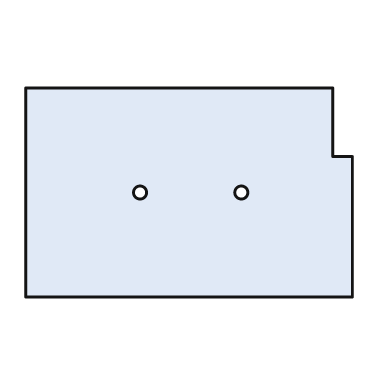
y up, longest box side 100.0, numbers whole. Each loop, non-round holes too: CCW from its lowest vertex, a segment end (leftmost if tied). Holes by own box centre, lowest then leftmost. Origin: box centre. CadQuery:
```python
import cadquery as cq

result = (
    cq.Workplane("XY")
    .moveTo(-50.0, -32.0)
    .lineTo(50.0, -32.0)
    .lineTo(50.0, 11.0)
    .lineTo(44.0, 11.0)
    .lineTo(44.0, 32.0)
    .lineTo(-50.0, 32.0)
    .close()
    .moveTo(-15.0, 0.0)
    .circle(2.0)
    .moveTo(16.0, 0.0)
    .circle(2.0)
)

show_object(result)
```